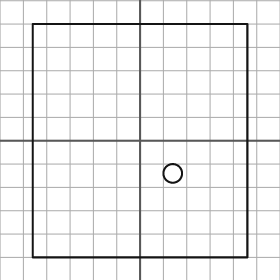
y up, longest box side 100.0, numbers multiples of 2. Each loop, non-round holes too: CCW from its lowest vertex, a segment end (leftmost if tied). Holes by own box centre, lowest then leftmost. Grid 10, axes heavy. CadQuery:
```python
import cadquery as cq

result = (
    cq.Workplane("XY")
    .moveTo(-46.0, -50.0)
    .lineTo(46.0, -50.0)
    .lineTo(46.0, 50.0)
    .lineTo(-46.0, 50.0)
    .close()
    .moveTo(14.0, -14.0)
    .circle(4.0)
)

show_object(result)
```